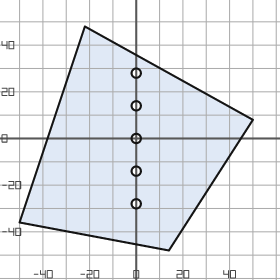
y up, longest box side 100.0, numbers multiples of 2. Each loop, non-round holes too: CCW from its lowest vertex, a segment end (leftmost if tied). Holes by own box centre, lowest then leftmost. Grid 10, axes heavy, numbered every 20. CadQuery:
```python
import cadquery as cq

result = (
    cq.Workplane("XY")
    .moveTo(14.0, -48.0)
    .lineTo(50.0, 8.0)
    .lineTo(-22.0, 48.0)
    .lineTo(-50.0, -36.0)
    .close()
    .moveTo(0.0, -28.0)
    .circle(2.0)
    .moveTo(0.0, -14.0)
    .circle(2.0)
    .moveTo(0.0, 0.0)
    .circle(2.0)
    .moveTo(0.0, 14.0)
    .circle(2.0)
    .moveTo(0.0, 28.0)
    .circle(2.0)
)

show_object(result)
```